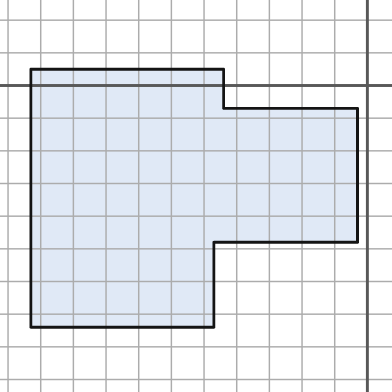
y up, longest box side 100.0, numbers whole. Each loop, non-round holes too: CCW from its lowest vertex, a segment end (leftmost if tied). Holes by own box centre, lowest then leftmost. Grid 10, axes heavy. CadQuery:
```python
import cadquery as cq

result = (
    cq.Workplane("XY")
    .moveTo(-103.0, -74.0)
    .lineTo(-47.0, -74.0)
    .lineTo(-47.0, -48.0)
    .lineTo(-3.0, -48.0)
    .lineTo(-3.0, -7.0)
    .lineTo(-44.0, -7.0)
    .lineTo(-44.0, 5.0)
    .lineTo(-103.0, 5.0)
    .close()
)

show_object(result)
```